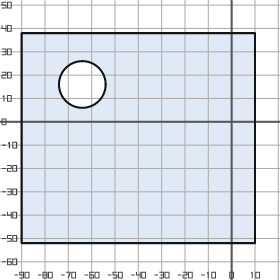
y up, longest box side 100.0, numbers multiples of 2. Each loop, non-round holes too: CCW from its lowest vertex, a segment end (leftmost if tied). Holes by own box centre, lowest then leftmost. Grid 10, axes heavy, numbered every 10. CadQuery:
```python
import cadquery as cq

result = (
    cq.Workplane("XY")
    .moveTo(-90.0, -52.0)
    .lineTo(10.0, -52.0)
    .lineTo(10.0, 38.0)
    .lineTo(-90.0, 38.0)
    .close()
    .moveTo(-64.0, 16.0)
    .circle(10.0)
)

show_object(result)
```